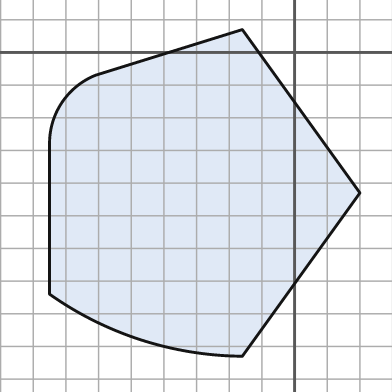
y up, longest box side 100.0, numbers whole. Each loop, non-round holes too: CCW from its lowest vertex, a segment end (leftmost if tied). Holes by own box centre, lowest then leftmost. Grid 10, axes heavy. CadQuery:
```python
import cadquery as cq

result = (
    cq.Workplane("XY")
    .moveTo(-16.0, -93.0)
    .lineTo(20.0, -43.0)
    .lineTo(-16.0, 7.0)
    .lineTo(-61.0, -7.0)
    .threePointArc((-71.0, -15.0), (-75.0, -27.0))
    .lineTo(-75.0, -74.0)
    .threePointArc((-47.0, -88.0), (-16.0, -93.0))
    .close()
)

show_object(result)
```